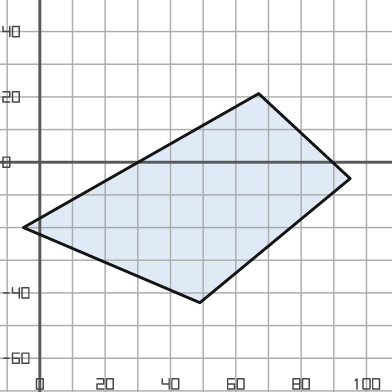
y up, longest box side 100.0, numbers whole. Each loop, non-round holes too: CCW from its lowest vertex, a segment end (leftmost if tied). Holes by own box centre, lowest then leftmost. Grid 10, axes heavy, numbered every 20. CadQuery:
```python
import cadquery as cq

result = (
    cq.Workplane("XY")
    .moveTo(49.0, -43.0)
    .lineTo(95.0, -5.0)
    .lineTo(67.0, 21.0)
    .lineTo(-5.0, -20.0)
    .close()
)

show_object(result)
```